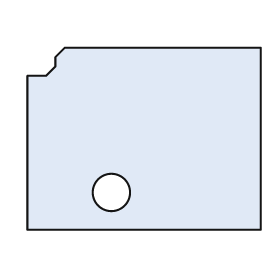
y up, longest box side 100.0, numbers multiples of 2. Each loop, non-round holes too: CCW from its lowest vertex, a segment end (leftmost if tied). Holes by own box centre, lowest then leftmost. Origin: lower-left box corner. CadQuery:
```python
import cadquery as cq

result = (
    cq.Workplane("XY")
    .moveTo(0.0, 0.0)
    .lineTo(100.0, 0.0)
    .lineTo(100.0, 78.0)
    .lineTo(16.0, 78.0)
    .lineTo(12.0, 74.0)
    .lineTo(12.0, 70.0)
    .lineTo(8.0, 66.0)
    .lineTo(0.0, 66.0)
    .close()
    .moveTo(36.0, 16.0)
    .circle(8.0)
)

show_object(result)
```